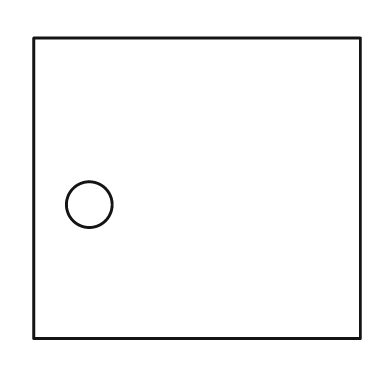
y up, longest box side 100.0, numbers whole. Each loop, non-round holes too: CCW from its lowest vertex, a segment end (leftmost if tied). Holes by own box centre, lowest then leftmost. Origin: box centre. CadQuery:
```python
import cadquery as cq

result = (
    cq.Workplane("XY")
    .moveTo(-50.0, -46.0)
    .lineTo(50.0, -46.0)
    .lineTo(50.0, 46.0)
    .lineTo(-50.0, 46.0)
    .close()
    .moveTo(-33.0, -5.0)
    .circle(7.0)
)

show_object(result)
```